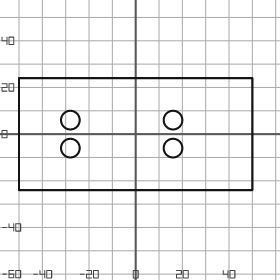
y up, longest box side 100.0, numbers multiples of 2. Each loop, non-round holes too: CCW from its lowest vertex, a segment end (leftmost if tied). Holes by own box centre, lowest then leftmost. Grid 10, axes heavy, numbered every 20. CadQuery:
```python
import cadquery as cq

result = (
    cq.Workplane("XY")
    .moveTo(-50.0, -24.0)
    .lineTo(50.0, -24.0)
    .lineTo(50.0, 24.0)
    .lineTo(-50.0, 24.0)
    .close()
    .moveTo(-28.0, -6.0)
    .circle(4.0)
    .moveTo(16.0, -6.0)
    .circle(4.0)
    .moveTo(-28.0, 6.0)
    .circle(4.0)
    .moveTo(16.0, 6.0)
    .circle(4.0)
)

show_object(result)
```